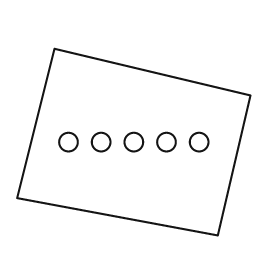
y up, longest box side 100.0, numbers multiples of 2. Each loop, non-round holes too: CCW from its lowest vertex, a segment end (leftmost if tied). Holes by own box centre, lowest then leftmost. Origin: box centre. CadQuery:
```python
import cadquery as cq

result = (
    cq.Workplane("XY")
    .moveTo(36.0, -40.0)
    .lineTo(50.0, 20.0)
    .lineTo(-34.0, 40.0)
    .lineTo(-50.0, -24.0)
    .close()
    .moveTo(-28.0, 0.0)
    .circle(4.0)
    .moveTo(-14.0, 0.0)
    .circle(4.0)
    .moveTo(0.0, 0.0)
    .circle(4.0)
    .moveTo(14.0, 0.0)
    .circle(4.0)
    .moveTo(28.0, 0.0)
    .circle(4.0)
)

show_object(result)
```